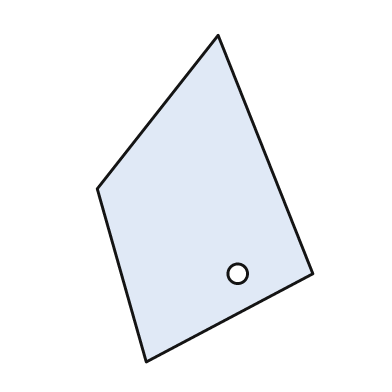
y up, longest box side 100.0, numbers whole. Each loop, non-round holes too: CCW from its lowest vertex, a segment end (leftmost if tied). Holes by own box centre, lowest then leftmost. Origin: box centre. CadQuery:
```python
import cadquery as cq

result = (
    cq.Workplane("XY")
    .moveTo(-18.0, -50.0)
    .lineTo(33.0, -23.0)
    .lineTo(4.0, 50.0)
    .lineTo(-33.0, 3.0)
    .close()
    .moveTo(10.0, -23.0)
    .circle(3.0)
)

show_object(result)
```